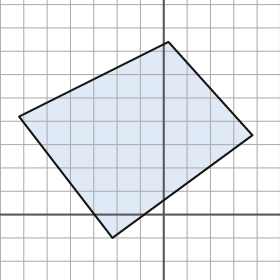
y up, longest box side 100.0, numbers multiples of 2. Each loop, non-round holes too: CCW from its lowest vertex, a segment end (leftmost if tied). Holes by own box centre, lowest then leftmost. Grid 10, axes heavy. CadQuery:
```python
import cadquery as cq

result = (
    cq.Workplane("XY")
    .moveTo(-22.0, -10.0)
    .lineTo(38.0, 34.0)
    .lineTo(2.0, 74.0)
    .lineTo(-62.0, 42.0)
    .close()
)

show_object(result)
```